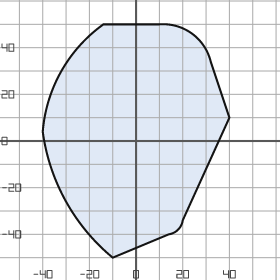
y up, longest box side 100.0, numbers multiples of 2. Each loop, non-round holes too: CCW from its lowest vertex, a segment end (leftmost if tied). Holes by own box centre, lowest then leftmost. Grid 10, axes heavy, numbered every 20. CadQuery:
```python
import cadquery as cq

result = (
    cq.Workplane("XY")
    .moveTo(-10.0, -50.0)
    .lineTo(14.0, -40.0)
    .threePointArc((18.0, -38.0), (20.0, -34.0))
    .lineTo(40.0, 10.0)
    .lineTo(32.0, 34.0)
    .threePointArc((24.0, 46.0), (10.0, 50.0))
    .lineTo(-14.0, 50.0)
    .threePointArc((-32.0, 30.0), (-40.0, 4.0))
    .threePointArc((-30.0, -26.0), (-10.0, -50.0))
    .close()
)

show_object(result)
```